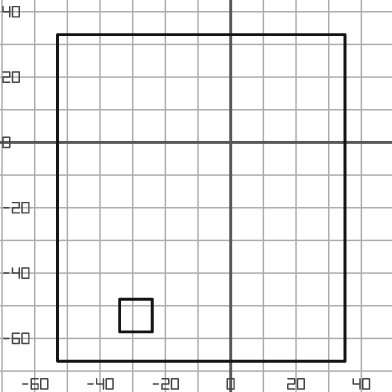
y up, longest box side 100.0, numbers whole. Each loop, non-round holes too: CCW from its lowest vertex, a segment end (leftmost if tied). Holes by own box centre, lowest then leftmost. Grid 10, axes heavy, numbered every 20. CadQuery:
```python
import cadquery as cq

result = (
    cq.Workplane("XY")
    .moveTo(-53.0, -67.0)
    .lineTo(35.0, -67.0)
    .lineTo(35.0, 33.0)
    .lineTo(-53.0, 33.0)
    .close()
    .moveTo(-34.0, -58.0)
    .lineTo(-24.0, -58.0)
    .lineTo(-24.0, -48.0)
    .lineTo(-34.0, -48.0)
    .close()
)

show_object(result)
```